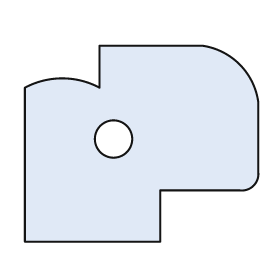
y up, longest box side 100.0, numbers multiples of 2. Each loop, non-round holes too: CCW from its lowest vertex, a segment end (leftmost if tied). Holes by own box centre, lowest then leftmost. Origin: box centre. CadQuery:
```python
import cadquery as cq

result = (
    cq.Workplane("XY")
    .moveTo(-50.0, -42.0)
    .lineTo(8.0, -42.0)
    .lineTo(8.0, -20.0)
    .lineTo(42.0, -20.0)
    .threePointArc((48.0, -18.0), (50.0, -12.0))
    .lineTo(50.0, 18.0)
    .threePointArc((42.0, 34.0), (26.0, 42.0))
    .lineTo(-18.0, 42.0)
    .lineTo(-18.0, 24.0)
    .threePointArc((-34.0, 28.0), (-50.0, 24.0))
    .close()
    .moveTo(-12.0, 2.0)
    .circle(8.0)
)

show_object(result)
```